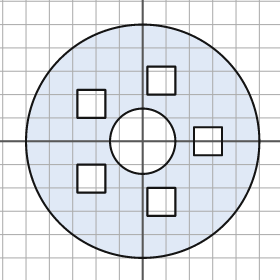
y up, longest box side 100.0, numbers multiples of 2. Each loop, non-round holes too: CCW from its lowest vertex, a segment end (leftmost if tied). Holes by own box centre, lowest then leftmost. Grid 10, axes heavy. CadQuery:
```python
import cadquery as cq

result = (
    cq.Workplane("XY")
    .moveTo(0.0, 0.0)
    .circle(50.0)
    .moveTo(2.0, -32.0)
    .lineTo(14.0, -32.0)
    .lineTo(14.0, -20.0)
    .lineTo(2.0, -20.0)
    .close()
    .moveTo(-28.0, -22.0)
    .lineTo(-16.0, -22.0)
    .lineTo(-16.0, -10.0)
    .lineTo(-28.0, -10.0)
    .close()
    .moveTo(0.0, 0.0)
    .circle(14.0)
    .moveTo(22.0, -6.0)
    .lineTo(34.0, -6.0)
    .lineTo(34.0, 6.0)
    .lineTo(22.0, 6.0)
    .close()
    .moveTo(-28.0, 10.0)
    .lineTo(-16.0, 10.0)
    .lineTo(-16.0, 22.0)
    .lineTo(-28.0, 22.0)
    .close()
    .moveTo(2.0, 20.0)
    .lineTo(14.0, 20.0)
    .lineTo(14.0, 32.0)
    .lineTo(2.0, 32.0)
    .close()
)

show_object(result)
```